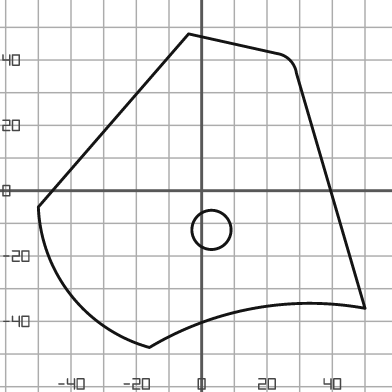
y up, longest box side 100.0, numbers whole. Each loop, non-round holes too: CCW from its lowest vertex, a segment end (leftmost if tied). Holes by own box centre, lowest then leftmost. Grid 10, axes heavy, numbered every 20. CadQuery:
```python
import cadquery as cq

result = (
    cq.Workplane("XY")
    .moveTo(-16.0, -48.0)
    .threePointArc((16.0, -36.0), (50.0, -36.0))
    .lineTo(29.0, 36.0)
    .threePointArc((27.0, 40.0), (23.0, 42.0))
    .lineTo(-4.0, 48.0)
    .lineTo(-50.0, -5.0)
    .threePointArc((-40.0, -32.0), (-16.0, -48.0))
    .close()
    .moveTo(3.0, -12.0)
    .circle(6.0)
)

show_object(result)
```